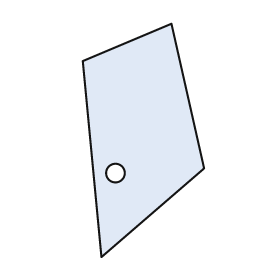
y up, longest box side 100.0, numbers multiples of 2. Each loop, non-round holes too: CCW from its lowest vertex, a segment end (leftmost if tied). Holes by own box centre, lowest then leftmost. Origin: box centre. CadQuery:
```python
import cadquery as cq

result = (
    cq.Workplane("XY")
    .moveTo(-18.0, -50.0)
    .lineTo(26.0, -12.0)
    .lineTo(12.0, 50.0)
    .lineTo(-26.0, 34.0)
    .close()
    .moveTo(-12.0, -14.0)
    .circle(4.0)
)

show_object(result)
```